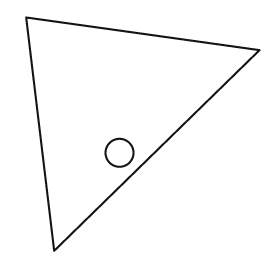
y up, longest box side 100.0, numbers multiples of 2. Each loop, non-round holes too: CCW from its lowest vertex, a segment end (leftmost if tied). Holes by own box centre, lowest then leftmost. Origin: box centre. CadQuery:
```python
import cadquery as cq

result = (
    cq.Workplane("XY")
    .moveTo(-38.0, -50.0)
    .lineTo(50.0, 36.0)
    .lineTo(-50.0, 50.0)
    .close()
    .moveTo(-10.0, -8.0)
    .circle(6.0)
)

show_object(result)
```